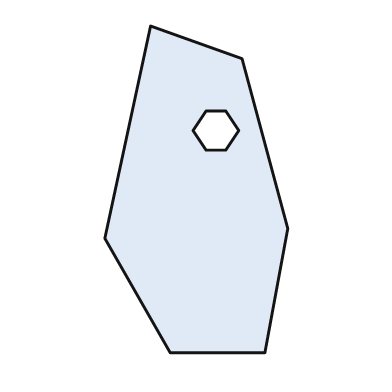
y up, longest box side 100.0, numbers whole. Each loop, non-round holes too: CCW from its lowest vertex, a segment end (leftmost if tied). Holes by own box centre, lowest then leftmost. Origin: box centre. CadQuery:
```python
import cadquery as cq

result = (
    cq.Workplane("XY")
    .moveTo(-8.0, -50.0)
    .lineTo(21.0, -50.0)
    .lineTo(28.0, -12.0)
    .lineTo(14.0, 40.0)
    .lineTo(-14.0, 50.0)
    .lineTo(-28.0, -15.0)
    .close()
    .moveTo(3.0, 12.0)
    .lineTo(9.0, 12.0)
    .lineTo(13.0, 18.0)
    .lineTo(9.0, 24.0)
    .lineTo(3.0, 24.0)
    .lineTo(-1.0, 18.0)
    .close()
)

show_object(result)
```